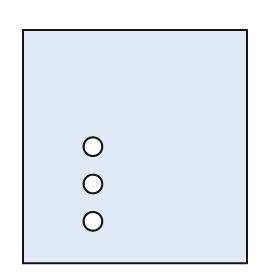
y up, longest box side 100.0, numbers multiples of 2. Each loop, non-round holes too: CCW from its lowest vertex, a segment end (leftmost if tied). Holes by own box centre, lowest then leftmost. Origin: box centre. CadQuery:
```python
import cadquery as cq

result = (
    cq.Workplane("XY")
    .moveTo(-48.0, -50.0)
    .lineTo(48.0, -50.0)
    .lineTo(48.0, 50.0)
    .lineTo(-48.0, 50.0)
    .close()
    .moveTo(-18.0, -32.0)
    .circle(4.0)
    .moveTo(-18.0, -16.0)
    .circle(4.0)
    .moveTo(-18.0, 0.0)
    .circle(4.0)
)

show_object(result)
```